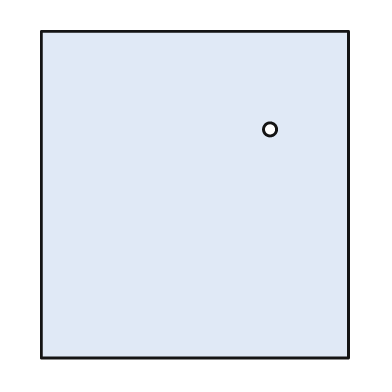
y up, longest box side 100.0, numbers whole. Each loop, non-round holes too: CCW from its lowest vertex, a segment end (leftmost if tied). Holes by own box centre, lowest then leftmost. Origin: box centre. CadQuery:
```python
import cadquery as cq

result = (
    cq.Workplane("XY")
    .moveTo(-47.0, -50.0)
    .lineTo(47.0, -50.0)
    .lineTo(47.0, 50.0)
    .lineTo(-47.0, 50.0)
    .close()
    .moveTo(23.0, 20.0)
    .circle(2.0)
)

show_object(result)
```